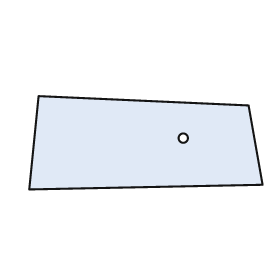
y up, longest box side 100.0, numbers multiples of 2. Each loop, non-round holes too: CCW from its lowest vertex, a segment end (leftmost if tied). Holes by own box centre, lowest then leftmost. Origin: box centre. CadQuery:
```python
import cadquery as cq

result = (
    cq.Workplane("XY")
    .moveTo(-50.0, -20.0)
    .lineTo(50.0, -18.0)
    .lineTo(44.0, 16.0)
    .lineTo(-46.0, 20.0)
    .close()
    .moveTo(16.0, 2.0)
    .circle(2.0)
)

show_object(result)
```